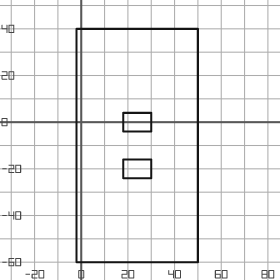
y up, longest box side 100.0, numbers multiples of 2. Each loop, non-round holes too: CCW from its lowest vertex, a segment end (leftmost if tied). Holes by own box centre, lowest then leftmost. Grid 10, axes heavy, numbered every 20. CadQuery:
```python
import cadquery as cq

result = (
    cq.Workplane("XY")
    .moveTo(-2.0, -60.0)
    .lineTo(50.0, -60.0)
    .lineTo(50.0, 40.0)
    .lineTo(-2.0, 40.0)
    .close()
    .moveTo(18.0, -24.0)
    .lineTo(30.0, -24.0)
    .lineTo(30.0, -16.0)
    .lineTo(18.0, -16.0)
    .close()
    .moveTo(18.0, -4.0)
    .lineTo(30.0, -4.0)
    .lineTo(30.0, 4.0)
    .lineTo(18.0, 4.0)
    .close()
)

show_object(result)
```